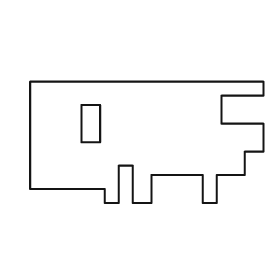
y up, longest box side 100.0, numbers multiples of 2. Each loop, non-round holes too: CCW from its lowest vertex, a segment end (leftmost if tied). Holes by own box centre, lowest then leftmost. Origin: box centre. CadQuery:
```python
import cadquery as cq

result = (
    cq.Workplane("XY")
    .moveTo(-18.0, -26.0)
    .lineTo(-12.0, -26.0)
    .lineTo(-12.0, -10.0)
    .lineTo(-6.0, -10.0)
    .lineTo(-6.0, -26.0)
    .lineTo(2.0, -26.0)
    .lineTo(2.0, -14.0)
    .lineTo(24.0, -14.0)
    .lineTo(24.0, -26.0)
    .lineTo(30.0, -26.0)
    .lineTo(30.0, -14.0)
    .lineTo(42.0, -14.0)
    .lineTo(42.0, -4.0)
    .lineTo(50.0, -4.0)
    .lineTo(50.0, 8.0)
    .lineTo(32.0, 8.0)
    .lineTo(32.0, 20.0)
    .lineTo(50.0, 20.0)
    .lineTo(50.0, 26.0)
    .lineTo(-50.0, 26.0)
    .lineTo(-50.0, -20.0)
    .lineTo(-18.0, -20.0)
    .close()
    .moveTo(-28.0, 0.0)
    .lineTo(-20.0, 0.0)
    .lineTo(-20.0, 16.0)
    .lineTo(-28.0, 16.0)
    .close()
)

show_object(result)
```